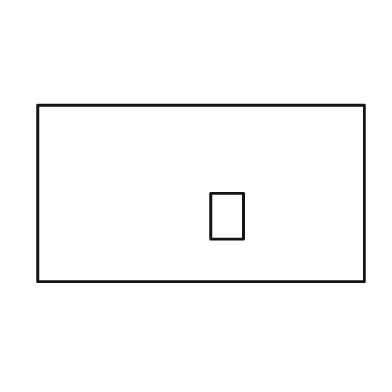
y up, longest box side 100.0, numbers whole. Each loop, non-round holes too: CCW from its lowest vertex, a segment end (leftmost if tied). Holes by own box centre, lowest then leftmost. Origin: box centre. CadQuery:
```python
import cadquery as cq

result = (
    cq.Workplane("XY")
    .moveTo(-50.0, -27.0)
    .lineTo(50.0, -27.0)
    .lineTo(50.0, 27.0)
    .lineTo(-50.0, 27.0)
    .close()
    .moveTo(3.0, -14.0)
    .lineTo(13.0, -14.0)
    .lineTo(13.0, 0.0)
    .lineTo(3.0, 0.0)
    .close()
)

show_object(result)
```